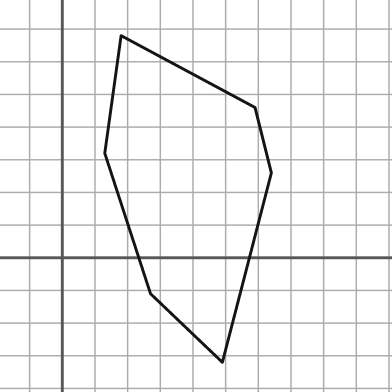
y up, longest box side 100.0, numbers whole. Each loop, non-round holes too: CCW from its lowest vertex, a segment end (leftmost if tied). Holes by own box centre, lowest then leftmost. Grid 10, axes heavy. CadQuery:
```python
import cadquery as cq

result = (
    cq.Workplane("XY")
    .moveTo(49.0, -32.0)
    .lineTo(64.0, 26.0)
    .lineTo(59.0, 46.0)
    .lineTo(18.0, 68.0)
    .lineTo(13.0, 32.0)
    .lineTo(27.0, -11.0)
    .close()
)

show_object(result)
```